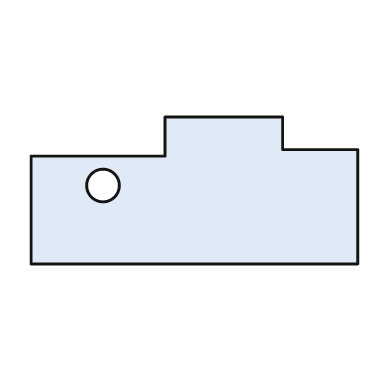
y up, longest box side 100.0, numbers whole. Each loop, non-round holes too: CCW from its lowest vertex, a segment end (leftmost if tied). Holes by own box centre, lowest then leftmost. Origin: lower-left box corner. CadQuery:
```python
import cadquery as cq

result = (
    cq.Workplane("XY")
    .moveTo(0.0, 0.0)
    .lineTo(100.0, 0.0)
    .lineTo(100.0, 35.0)
    .lineTo(77.0, 35.0)
    .lineTo(77.0, 45.0)
    .lineTo(41.0, 45.0)
    .lineTo(41.0, 33.0)
    .lineTo(0.0, 33.0)
    .close()
    .moveTo(22.0, 24.0)
    .circle(5.0)
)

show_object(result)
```